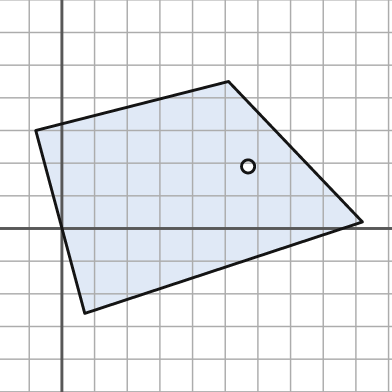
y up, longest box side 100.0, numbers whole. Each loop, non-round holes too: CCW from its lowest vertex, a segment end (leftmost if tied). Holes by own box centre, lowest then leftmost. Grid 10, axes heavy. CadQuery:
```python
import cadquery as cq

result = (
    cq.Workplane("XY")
    .moveTo(7.0, -26.0)
    .lineTo(92.0, 2.0)
    .lineTo(51.0, 45.0)
    .lineTo(-8.0, 30.0)
    .close()
    .moveTo(57.0, 19.0)
    .circle(2.0)
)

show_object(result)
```